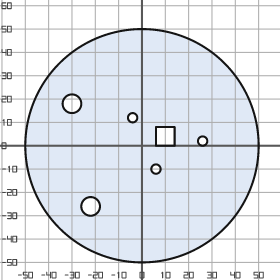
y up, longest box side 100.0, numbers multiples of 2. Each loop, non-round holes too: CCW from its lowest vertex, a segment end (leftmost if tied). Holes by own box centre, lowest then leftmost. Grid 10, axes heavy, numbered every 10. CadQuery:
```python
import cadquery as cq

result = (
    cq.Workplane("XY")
    .moveTo(0.0, 0.0)
    .circle(50.0)
    .moveTo(-22.0, -26.0)
    .circle(4.0)
    .moveTo(6.0, -10.0)
    .circle(2.0)
    .moveTo(26.0, 2.0)
    .circle(2.0)
    .moveTo(6.0, 0.0)
    .lineTo(14.0, 0.0)
    .lineTo(14.0, 8.0)
    .lineTo(6.0, 8.0)
    .close()
    .moveTo(-4.0, 12.0)
    .circle(2.0)
    .moveTo(-30.0, 18.0)
    .circle(4.0)
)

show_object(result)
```